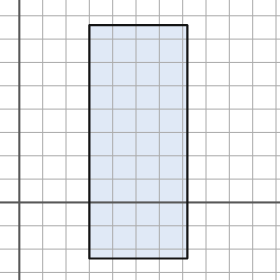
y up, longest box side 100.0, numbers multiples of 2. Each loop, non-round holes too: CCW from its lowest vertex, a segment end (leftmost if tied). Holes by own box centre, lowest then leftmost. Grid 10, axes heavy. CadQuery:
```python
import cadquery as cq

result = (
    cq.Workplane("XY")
    .moveTo(30.0, -24.0)
    .lineTo(72.0, -24.0)
    .lineTo(72.0, 76.0)
    .lineTo(30.0, 76.0)
    .close()
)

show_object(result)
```